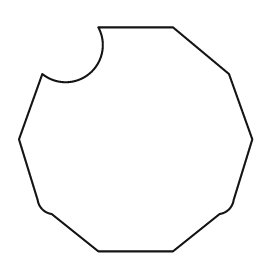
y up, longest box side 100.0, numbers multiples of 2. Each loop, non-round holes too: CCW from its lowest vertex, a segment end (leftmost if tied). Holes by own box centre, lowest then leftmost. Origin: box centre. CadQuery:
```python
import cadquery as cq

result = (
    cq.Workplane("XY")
    .moveTo(-16.0, -48.0)
    .lineTo(16.0, -48.0)
    .lineTo(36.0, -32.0)
    .threePointArc((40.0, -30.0), (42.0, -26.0))
    .lineTo(50.0, 0.0)
    .lineTo(40.0, 28.0)
    .lineTo(16.0, 48.0)
    .lineTo(-16.0, 48.0)
    .threePointArc((-20.0, 28.0), (-40.0, 28.0))
    .lineTo(-50.0, 0.0)
    .lineTo(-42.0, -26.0)
    .threePointArc((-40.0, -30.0), (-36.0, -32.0))
    .close()
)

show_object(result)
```